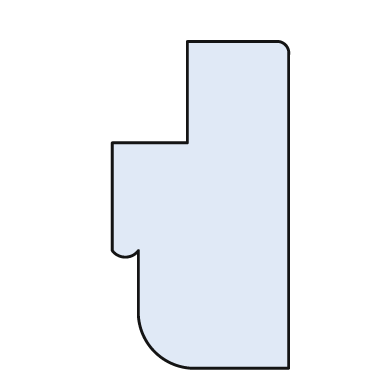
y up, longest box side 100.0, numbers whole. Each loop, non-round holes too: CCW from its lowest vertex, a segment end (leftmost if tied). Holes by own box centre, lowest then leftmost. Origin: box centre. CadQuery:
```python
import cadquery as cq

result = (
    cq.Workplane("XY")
    .moveTo(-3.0, -50.0)
    .lineTo(27.0, -50.0)
    .lineTo(27.0, 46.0)
    .threePointArc((26.0, 49.0), (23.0, 50.0))
    .lineTo(-4.0, 50.0)
    .lineTo(-4.0, 19.0)
    .lineTo(-27.0, 19.0)
    .lineTo(-27.0, -14.0)
    .threePointArc((-23.0, -16.0), (-19.0, -14.0))
    .lineTo(-19.0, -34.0)
    .threePointArc((-14.0, -45.0), (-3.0, -50.0))
    .close()
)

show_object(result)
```